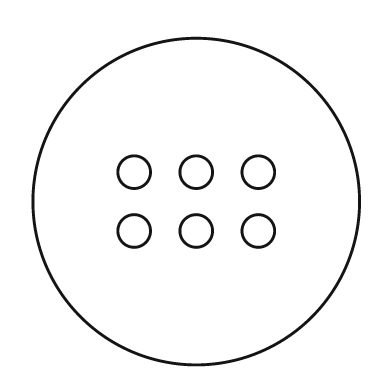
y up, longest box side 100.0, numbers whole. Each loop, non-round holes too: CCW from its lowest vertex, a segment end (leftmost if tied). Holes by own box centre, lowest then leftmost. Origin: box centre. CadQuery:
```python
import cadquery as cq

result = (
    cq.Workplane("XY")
    .moveTo(0.0, 0.0)
    .circle(50.0)
    .moveTo(-19.0, -9.0)
    .circle(5.0)
    .moveTo(0.0, -9.0)
    .circle(5.0)
    .moveTo(19.0, -9.0)
    .circle(5.0)
    .moveTo(-19.0, 9.0)
    .circle(5.0)
    .moveTo(0.0, 9.0)
    .circle(5.0)
    .moveTo(19.0, 9.0)
    .circle(5.0)
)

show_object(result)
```